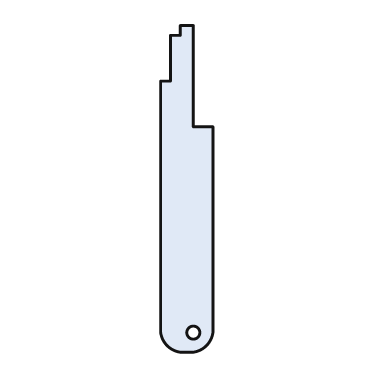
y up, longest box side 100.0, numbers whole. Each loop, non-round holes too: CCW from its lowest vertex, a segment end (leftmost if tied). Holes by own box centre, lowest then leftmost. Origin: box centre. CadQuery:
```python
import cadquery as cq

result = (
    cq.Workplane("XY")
    .moveTo(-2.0, -50.0)
    .lineTo(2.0, -50.0)
    .threePointArc((6.0, -48.0), (8.0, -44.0))
    .lineTo(8.0, 19.0)
    .lineTo(2.0, 19.0)
    .lineTo(2.0, 50.0)
    .lineTo(-2.0, 50.0)
    .lineTo(-2.0, 47.0)
    .lineTo(-5.0, 47.0)
    .lineTo(-5.0, 33.0)
    .lineTo(-8.0, 33.0)
    .lineTo(-8.0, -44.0)
    .threePointArc((-6.0, -48.0), (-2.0, -50.0))
    .close()
    .moveTo(2.0, -44.0)
    .circle(2.0)
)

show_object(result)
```